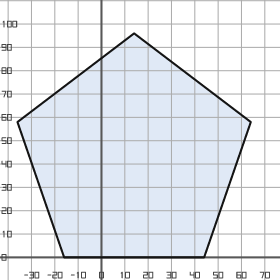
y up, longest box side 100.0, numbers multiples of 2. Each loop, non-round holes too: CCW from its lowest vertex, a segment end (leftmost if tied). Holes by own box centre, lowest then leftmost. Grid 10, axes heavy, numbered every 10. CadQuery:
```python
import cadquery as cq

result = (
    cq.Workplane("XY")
    .moveTo(-16.0, 0.0)
    .lineTo(44.0, 0.0)
    .lineTo(64.0, 58.0)
    .lineTo(14.0, 96.0)
    .lineTo(-36.0, 58.0)
    .close()
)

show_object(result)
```